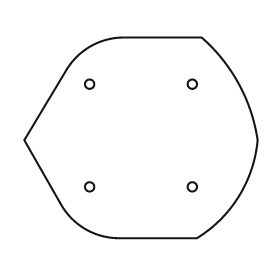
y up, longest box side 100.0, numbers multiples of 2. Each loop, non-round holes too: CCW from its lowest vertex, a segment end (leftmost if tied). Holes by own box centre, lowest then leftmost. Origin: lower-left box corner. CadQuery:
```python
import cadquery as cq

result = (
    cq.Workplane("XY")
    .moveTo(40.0, 0.0)
    .lineTo(74.0, 0.0)
    .threePointArc((92.0, 18.0), (100.0, 42.0))
    .threePointArc((92.0, 66.0), (76.0, 86.0))
    .lineTo(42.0, 86.0)
    .threePointArc((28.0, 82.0), (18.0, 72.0))
    .lineTo(0.0, 42.0)
    .lineTo(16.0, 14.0)
    .threePointArc((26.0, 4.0), (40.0, 0.0))
    .close()
    .moveTo(28.0, 22.0)
    .circle(2.0)
    .moveTo(72.0, 22.0)
    .circle(2.0)
    .moveTo(28.0, 66.0)
    .circle(2.0)
    .moveTo(72.0, 66.0)
    .circle(2.0)
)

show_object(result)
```